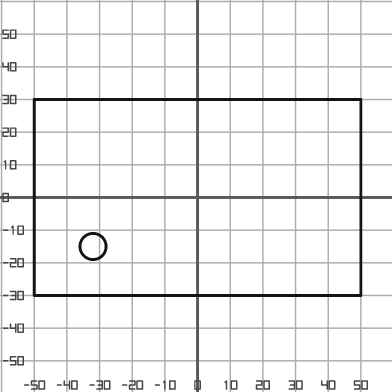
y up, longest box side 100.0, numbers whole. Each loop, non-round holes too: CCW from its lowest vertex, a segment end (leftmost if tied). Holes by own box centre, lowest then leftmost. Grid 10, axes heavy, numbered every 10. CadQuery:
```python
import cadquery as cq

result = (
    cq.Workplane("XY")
    .moveTo(-50.0, -30.0)
    .lineTo(50.0, -30.0)
    .lineTo(50.0, 30.0)
    .lineTo(-50.0, 30.0)
    .close()
    .moveTo(-32.0, -15.0)
    .circle(4.0)
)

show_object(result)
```